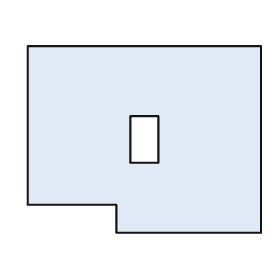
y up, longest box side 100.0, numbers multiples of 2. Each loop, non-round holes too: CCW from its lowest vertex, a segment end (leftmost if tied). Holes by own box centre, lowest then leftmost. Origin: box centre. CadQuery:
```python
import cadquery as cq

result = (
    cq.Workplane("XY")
    .moveTo(-12.0, -40.0)
    .lineTo(50.0, -40.0)
    .lineTo(50.0, 40.0)
    .lineTo(-50.0, 40.0)
    .lineTo(-50.0, -28.0)
    .lineTo(-12.0, -28.0)
    .close()
    .moveTo(-6.0, -10.0)
    .lineTo(6.0, -10.0)
    .lineTo(6.0, 10.0)
    .lineTo(-6.0, 10.0)
    .close()
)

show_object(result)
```